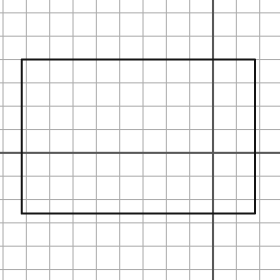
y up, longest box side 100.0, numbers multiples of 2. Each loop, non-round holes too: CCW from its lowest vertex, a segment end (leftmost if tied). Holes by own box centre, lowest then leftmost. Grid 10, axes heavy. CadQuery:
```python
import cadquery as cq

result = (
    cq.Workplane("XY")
    .moveTo(-82.0, -26.0)
    .lineTo(18.0, -26.0)
    .lineTo(18.0, 40.0)
    .lineTo(-82.0, 40.0)
    .close()
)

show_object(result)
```